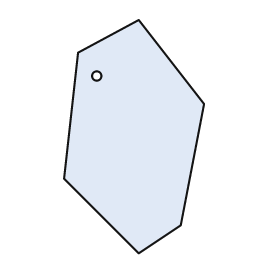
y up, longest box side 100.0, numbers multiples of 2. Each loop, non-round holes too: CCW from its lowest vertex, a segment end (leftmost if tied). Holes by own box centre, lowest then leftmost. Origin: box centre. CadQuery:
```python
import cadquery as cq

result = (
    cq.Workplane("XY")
    .moveTo(2.0, -50.0)
    .lineTo(20.0, -38.0)
    .lineTo(30.0, 14.0)
    .lineTo(2.0, 50.0)
    .lineTo(-24.0, 36.0)
    .lineTo(-30.0, -18.0)
    .close()
    .moveTo(-16.0, 26.0)
    .circle(2.0)
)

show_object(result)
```